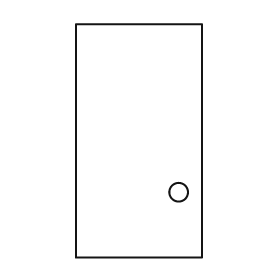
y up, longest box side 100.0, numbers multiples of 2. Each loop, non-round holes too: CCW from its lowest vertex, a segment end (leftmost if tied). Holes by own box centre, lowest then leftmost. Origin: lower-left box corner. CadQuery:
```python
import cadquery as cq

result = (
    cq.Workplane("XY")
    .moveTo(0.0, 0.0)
    .lineTo(54.0, 0.0)
    .lineTo(54.0, 100.0)
    .lineTo(0.0, 100.0)
    .close()
    .moveTo(44.0, 28.0)
    .circle(4.0)
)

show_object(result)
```